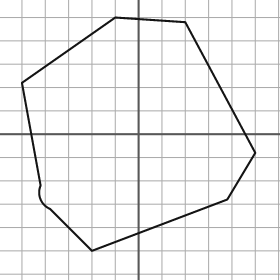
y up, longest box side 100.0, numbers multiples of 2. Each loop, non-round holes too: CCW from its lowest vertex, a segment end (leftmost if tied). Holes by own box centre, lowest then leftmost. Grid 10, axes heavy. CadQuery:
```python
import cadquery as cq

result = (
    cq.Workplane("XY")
    .moveTo(-20.0, -50.0)
    .lineTo(38.0, -28.0)
    .lineTo(50.0, -8.0)
    .lineTo(20.0, 48.0)
    .lineTo(-10.0, 50.0)
    .lineTo(-50.0, 22.0)
    .lineTo(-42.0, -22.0)
    .threePointArc((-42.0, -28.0), (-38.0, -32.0))
    .close()
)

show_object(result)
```